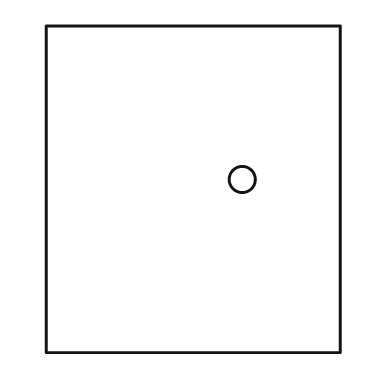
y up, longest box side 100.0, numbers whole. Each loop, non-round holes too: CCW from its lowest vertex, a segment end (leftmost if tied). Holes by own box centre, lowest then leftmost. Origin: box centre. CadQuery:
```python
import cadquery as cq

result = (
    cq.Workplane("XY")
    .moveTo(-45.0, -50.0)
    .lineTo(45.0, -50.0)
    .lineTo(45.0, 50.0)
    .lineTo(-45.0, 50.0)
    .close()
    .moveTo(15.0, 3.0)
    .circle(4.0)
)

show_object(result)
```